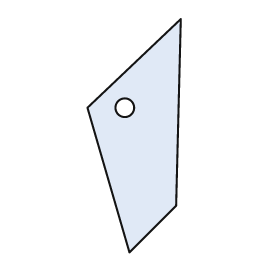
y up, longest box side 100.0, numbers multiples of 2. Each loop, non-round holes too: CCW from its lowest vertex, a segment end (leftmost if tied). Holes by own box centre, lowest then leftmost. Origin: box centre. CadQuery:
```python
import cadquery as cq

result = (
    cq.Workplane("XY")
    .moveTo(-2.0, -50.0)
    .lineTo(18.0, -30.0)
    .lineTo(20.0, 50.0)
    .lineTo(-20.0, 12.0)
    .close()
    .moveTo(-4.0, 12.0)
    .circle(4.0)
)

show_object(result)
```